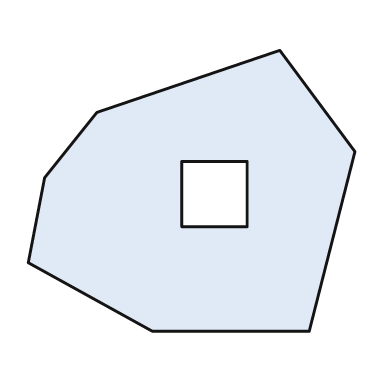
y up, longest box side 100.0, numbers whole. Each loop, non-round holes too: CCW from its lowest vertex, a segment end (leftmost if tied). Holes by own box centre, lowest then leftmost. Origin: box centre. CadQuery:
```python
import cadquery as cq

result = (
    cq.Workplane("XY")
    .moveTo(-12.0, -43.0)
    .lineTo(36.0, -43.0)
    .lineTo(50.0, 12.0)
    .lineTo(27.0, 43.0)
    .lineTo(-29.0, 24.0)
    .lineTo(-45.0, 4.0)
    .lineTo(-50.0, -22.0)
    .close()
    .moveTo(-3.0, -11.0)
    .lineTo(17.0, -11.0)
    .lineTo(17.0, 9.0)
    .lineTo(-3.0, 9.0)
    .close()
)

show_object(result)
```